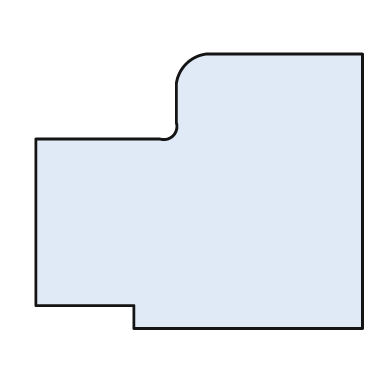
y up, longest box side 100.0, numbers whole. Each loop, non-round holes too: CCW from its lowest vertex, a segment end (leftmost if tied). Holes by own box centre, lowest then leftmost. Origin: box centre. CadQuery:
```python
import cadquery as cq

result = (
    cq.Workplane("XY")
    .moveTo(-20.0, -42.0)
    .lineTo(50.0, -42.0)
    .lineTo(50.0, 42.0)
    .lineTo(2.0, 42.0)
    .threePointArc((-4.0, 39.0), (-7.0, 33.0))
    .lineTo(-7.0, 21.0)
    .threePointArc((-8.0, 17.0), (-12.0, 16.0))
    .lineTo(-50.0, 16.0)
    .lineTo(-50.0, -35.0)
    .lineTo(-20.0, -35.0)
    .close()
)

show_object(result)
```